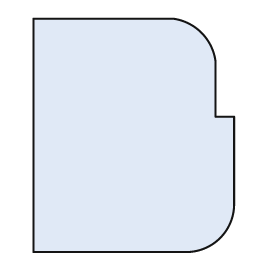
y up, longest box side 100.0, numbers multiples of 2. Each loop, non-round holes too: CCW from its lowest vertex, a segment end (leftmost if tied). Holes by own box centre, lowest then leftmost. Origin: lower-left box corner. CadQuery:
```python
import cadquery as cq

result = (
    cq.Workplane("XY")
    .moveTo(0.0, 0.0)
    .lineTo(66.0, 0.0)
    .threePointArc((80.0, 6.0), (86.0, 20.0))
    .lineTo(86.0, 58.0)
    .lineTo(78.0, 58.0)
    .lineTo(78.0, 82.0)
    .threePointArc((72.0, 94.0), (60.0, 100.0))
    .lineTo(0.0, 100.0)
    .close()
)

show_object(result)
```